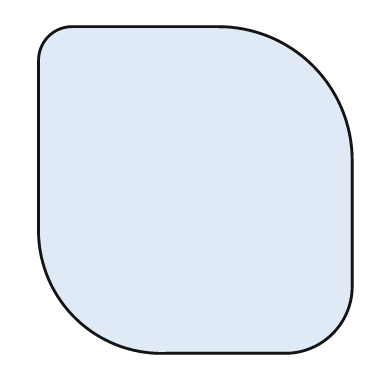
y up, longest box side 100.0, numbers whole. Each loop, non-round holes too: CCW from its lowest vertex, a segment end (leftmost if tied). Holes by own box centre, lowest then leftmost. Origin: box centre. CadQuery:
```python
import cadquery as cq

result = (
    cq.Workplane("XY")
    .moveTo(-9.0, -50.0)
    .lineTo(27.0, -50.0)
    .threePointArc((42.0, -44.0), (48.0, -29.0))
    .lineTo(48.0, 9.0)
    .threePointArc((36.0, 38.0), (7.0, 50.0))
    .lineTo(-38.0, 50.0)
    .threePointArc((-45.0, 47.0), (-48.0, 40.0))
    .lineTo(-48.0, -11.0)
    .threePointArc((-37.0, -39.0), (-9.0, -50.0))
    .close()
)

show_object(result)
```